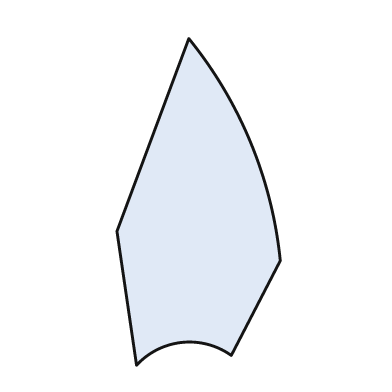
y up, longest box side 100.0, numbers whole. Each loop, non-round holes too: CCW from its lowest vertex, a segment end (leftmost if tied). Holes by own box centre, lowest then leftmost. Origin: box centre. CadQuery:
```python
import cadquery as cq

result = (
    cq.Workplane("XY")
    .moveTo(-19.0, -50.0)
    .threePointArc((-5.0, -43.0), (10.0, -47.0))
    .lineTo(25.0, -18.0)
    .threePointArc((16.0, 18.0), (-3.0, 50.0))
    .lineTo(-25.0, -9.0)
    .close()
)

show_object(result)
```